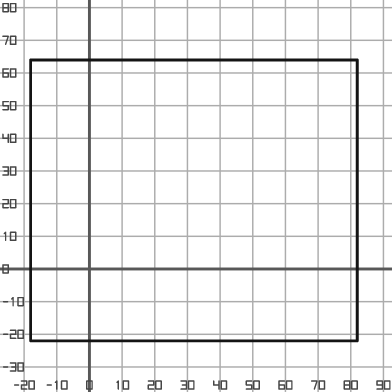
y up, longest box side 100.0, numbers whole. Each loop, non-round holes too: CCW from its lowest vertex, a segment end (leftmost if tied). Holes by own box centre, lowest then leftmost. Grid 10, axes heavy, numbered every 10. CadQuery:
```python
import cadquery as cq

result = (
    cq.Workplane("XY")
    .moveTo(-18.0, -22.0)
    .lineTo(82.0, -22.0)
    .lineTo(82.0, 64.0)
    .lineTo(-18.0, 64.0)
    .close()
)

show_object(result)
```